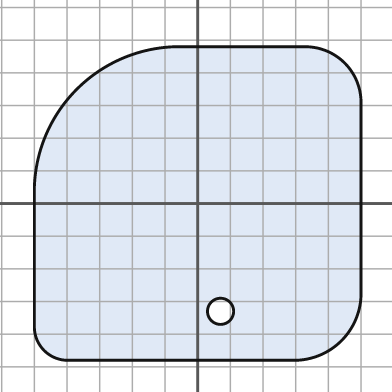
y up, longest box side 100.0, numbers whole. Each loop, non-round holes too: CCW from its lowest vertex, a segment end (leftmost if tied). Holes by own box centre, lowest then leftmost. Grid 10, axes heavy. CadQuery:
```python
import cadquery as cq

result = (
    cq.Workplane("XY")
    .moveTo(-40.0, -48.0)
    .lineTo(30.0, -48.0)
    .threePointArc((44.0, -42.0), (50.0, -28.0))
    .lineTo(50.0, 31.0)
    .threePointArc((45.0, 43.0), (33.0, 48.0))
    .lineTo(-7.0, 48.0)
    .threePointArc((-37.0, 35.0), (-50.0, 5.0))
    .lineTo(-50.0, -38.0)
    .threePointArc((-47.0, -45.0), (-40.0, -48.0))
    .close()
    .moveTo(7.0, -33.0)
    .circle(4.0)
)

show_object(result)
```